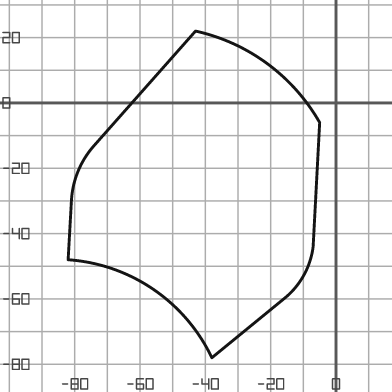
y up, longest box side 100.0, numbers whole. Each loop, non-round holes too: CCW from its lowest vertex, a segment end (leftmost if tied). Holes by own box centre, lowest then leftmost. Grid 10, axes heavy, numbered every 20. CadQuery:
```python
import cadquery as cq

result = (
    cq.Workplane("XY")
    .moveTo(-38.0, -78.0)
    .lineTo(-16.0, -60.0)
    .threePointArc((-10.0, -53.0), (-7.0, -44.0))
    .lineTo(-5.0, -6.0)
    .threePointArc((-21.0, 12.0), (-43.0, 22.0))
    .lineTo(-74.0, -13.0)
    .threePointArc((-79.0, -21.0), (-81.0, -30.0))
    .lineTo(-82.0, -48.0)
    .threePointArc((-56.0, -57.0), (-38.0, -78.0))
    .close()
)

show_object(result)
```